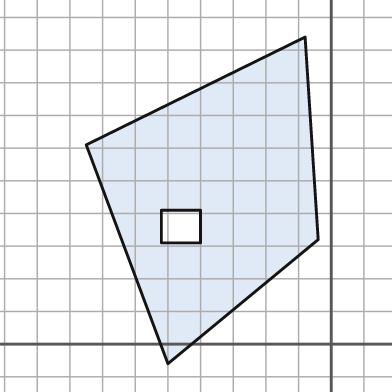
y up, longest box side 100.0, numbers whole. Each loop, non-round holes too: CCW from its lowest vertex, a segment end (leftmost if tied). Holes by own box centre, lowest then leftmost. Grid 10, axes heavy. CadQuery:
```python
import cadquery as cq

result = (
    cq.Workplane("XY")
    .moveTo(-50.0, -6.0)
    .lineTo(-4.0, 32.0)
    .lineTo(-8.0, 94.0)
    .lineTo(-75.0, 61.0)
    .close()
    .moveTo(-52.0, 31.0)
    .lineTo(-40.0, 31.0)
    .lineTo(-40.0, 41.0)
    .lineTo(-52.0, 41.0)
    .close()
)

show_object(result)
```